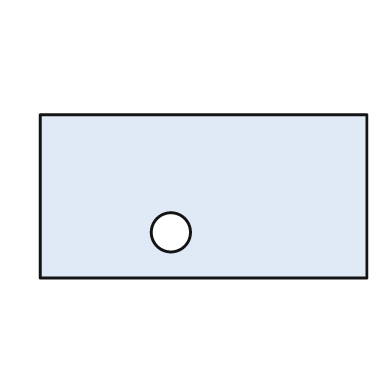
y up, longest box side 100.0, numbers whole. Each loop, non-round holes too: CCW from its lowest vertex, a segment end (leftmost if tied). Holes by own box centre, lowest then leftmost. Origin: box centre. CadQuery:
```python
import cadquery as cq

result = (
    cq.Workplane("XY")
    .moveTo(-50.0, -25.0)
    .lineTo(50.0, -25.0)
    .lineTo(50.0, 25.0)
    .lineTo(-50.0, 25.0)
    .close()
    .moveTo(-10.0, -11.0)
    .circle(6.0)
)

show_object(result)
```